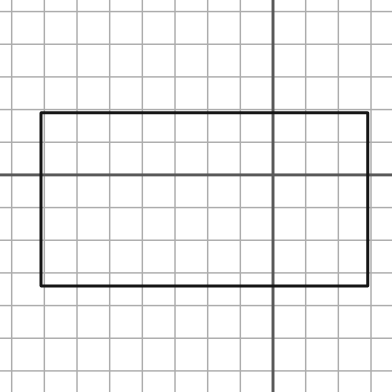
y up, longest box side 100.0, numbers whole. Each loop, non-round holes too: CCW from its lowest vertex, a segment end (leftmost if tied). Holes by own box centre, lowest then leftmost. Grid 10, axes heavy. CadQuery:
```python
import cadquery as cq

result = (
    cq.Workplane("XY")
    .moveTo(-71.0, -34.0)
    .lineTo(29.0, -34.0)
    .lineTo(29.0, 19.0)
    .lineTo(-71.0, 19.0)
    .close()
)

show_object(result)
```